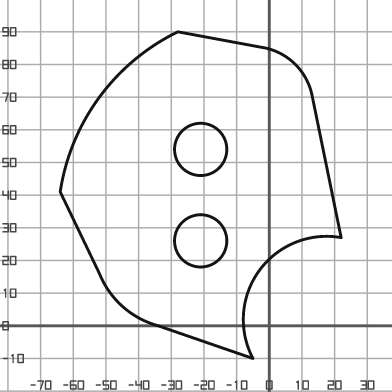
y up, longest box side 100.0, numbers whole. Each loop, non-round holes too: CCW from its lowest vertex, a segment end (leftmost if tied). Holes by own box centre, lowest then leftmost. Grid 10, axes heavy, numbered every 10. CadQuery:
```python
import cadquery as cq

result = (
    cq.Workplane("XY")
    .moveTo(-5.0, -10.0)
    .threePointArc((-3.0, 17.0), (22.0, 27.0))
    .lineTo(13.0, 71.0)
    .threePointArc((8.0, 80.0), (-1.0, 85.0))
    .lineTo(-28.0, 90.0)
    .threePointArc((-52.0, 70.0), (-64.0, 41.0))
    .lineTo(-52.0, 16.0)
    .threePointArc((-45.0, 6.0), (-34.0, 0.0))
    .close()
    .moveTo(-21.0, 26.0)
    .circle(8.0)
    .moveTo(-21.0, 54.0)
    .circle(8.0)
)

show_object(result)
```